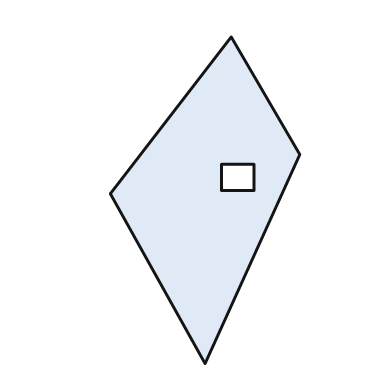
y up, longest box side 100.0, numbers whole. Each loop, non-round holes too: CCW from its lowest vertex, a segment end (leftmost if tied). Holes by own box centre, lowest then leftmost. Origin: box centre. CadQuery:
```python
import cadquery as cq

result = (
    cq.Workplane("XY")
    .moveTo(0.0, -50.0)
    .lineTo(29.0, 14.0)
    .lineTo(8.0, 50.0)
    .lineTo(-29.0, 2.0)
    .close()
    .moveTo(5.0, 3.0)
    .lineTo(15.0, 3.0)
    .lineTo(15.0, 11.0)
    .lineTo(5.0, 11.0)
    .close()
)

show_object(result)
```